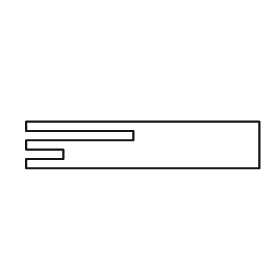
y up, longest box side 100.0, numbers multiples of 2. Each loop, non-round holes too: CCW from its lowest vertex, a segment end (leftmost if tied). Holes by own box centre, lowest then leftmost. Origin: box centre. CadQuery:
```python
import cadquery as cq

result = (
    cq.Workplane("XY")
    .moveTo(-50.0, -10.0)
    .lineTo(50.0, -10.0)
    .lineTo(50.0, 10.0)
    .lineTo(-50.0, 10.0)
    .lineTo(-50.0, 6.0)
    .lineTo(-4.0, 6.0)
    .lineTo(-4.0, 2.0)
    .lineTo(-50.0, 2.0)
    .lineTo(-50.0, -2.0)
    .lineTo(-34.0, -2.0)
    .lineTo(-34.0, -6.0)
    .lineTo(-50.0, -6.0)
    .close()
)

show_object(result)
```